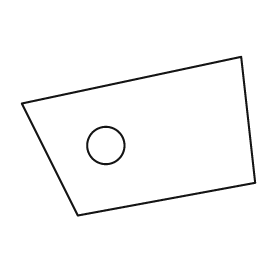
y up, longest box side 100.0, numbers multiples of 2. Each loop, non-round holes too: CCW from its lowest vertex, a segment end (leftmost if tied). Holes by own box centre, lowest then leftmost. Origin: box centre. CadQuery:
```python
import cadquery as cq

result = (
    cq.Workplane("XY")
    .moveTo(-26.0, -34.0)
    .lineTo(50.0, -20.0)
    .lineTo(44.0, 34.0)
    .lineTo(-50.0, 14.0)
    .close()
    .moveTo(-14.0, -4.0)
    .circle(8.0)
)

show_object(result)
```